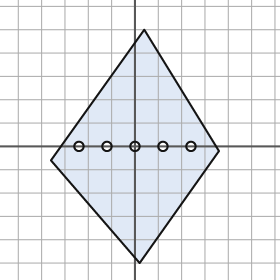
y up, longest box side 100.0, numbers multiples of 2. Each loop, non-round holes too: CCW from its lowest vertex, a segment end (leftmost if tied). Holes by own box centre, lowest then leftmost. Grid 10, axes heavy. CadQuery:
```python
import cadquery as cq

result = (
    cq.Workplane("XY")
    .moveTo(2.0, -50.0)
    .lineTo(36.0, -2.0)
    .lineTo(4.0, 50.0)
    .lineTo(-36.0, -6.0)
    .close()
    .moveTo(-24.0, 0.0)
    .circle(2.0)
    .moveTo(-12.0, 0.0)
    .circle(2.0)
    .moveTo(0.0, 0.0)
    .circle(2.0)
    .moveTo(12.0, 0.0)
    .circle(2.0)
    .moveTo(24.0, 0.0)
    .circle(2.0)
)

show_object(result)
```